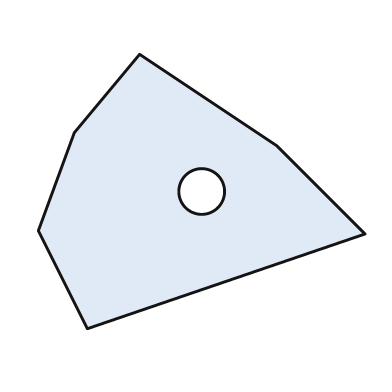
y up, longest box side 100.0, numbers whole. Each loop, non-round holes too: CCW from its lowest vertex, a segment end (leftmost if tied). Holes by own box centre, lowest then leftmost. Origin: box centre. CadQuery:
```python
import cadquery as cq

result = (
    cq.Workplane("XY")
    .moveTo(-35.0, -42.0)
    .lineTo(50.0, -13.0)
    .lineTo(23.0, 14.0)
    .lineTo(-19.0, 42.0)
    .lineTo(-39.0, 18.0)
    .lineTo(-50.0, -12.0)
    .close()
    .moveTo(0.0, 0.0)
    .circle(7.0)
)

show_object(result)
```